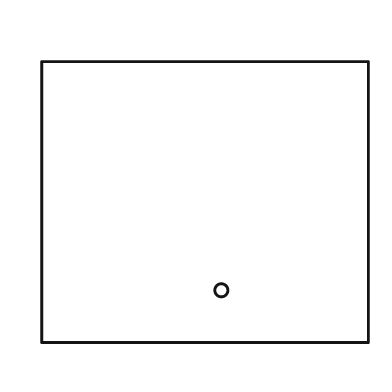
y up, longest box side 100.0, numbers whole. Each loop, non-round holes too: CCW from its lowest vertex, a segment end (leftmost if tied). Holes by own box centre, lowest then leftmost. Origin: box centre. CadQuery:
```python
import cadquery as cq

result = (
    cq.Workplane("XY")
    .moveTo(-50.0, -43.0)
    .lineTo(50.0, -43.0)
    .lineTo(50.0, 43.0)
    .lineTo(-50.0, 43.0)
    .close()
    .moveTo(5.0, -27.0)
    .circle(2.0)
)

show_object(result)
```